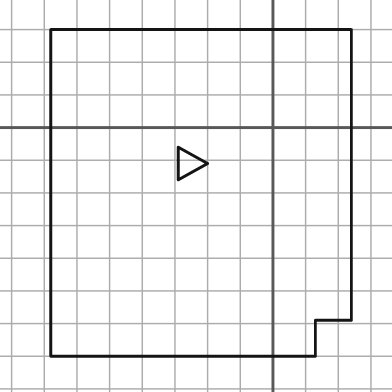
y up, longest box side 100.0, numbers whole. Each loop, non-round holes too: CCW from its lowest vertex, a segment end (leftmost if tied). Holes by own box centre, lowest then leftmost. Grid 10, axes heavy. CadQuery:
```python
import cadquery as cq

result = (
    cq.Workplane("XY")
    .moveTo(-68.0, -70.0)
    .lineTo(13.0, -70.0)
    .lineTo(13.0, -59.0)
    .lineTo(24.0, -59.0)
    .lineTo(24.0, 30.0)
    .lineTo(-68.0, 30.0)
    .close()
    .moveTo(-29.0, -16.0)
    .lineTo(-20.0, -11.0)
    .lineTo(-29.0, -6.0)
    .close()
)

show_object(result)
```